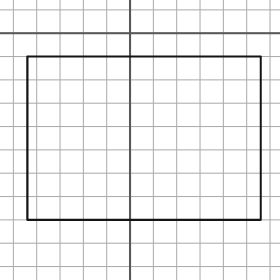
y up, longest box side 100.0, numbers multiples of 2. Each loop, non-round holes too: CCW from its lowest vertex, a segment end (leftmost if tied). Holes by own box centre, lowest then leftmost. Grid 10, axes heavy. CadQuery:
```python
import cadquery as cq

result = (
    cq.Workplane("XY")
    .moveTo(-44.0, -80.0)
    .lineTo(56.0, -80.0)
    .lineTo(56.0, -10.0)
    .lineTo(-44.0, -10.0)
    .close()
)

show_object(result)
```